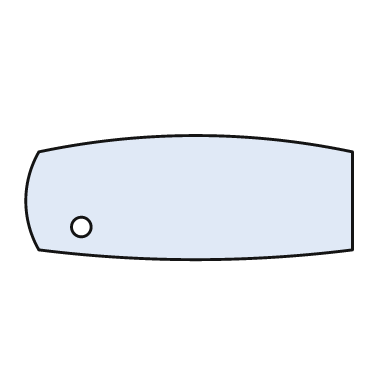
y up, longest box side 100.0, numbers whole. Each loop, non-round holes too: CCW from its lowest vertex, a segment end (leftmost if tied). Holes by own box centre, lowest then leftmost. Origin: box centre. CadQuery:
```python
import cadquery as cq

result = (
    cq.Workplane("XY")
    .moveTo(-46.0, -16.0)
    .threePointArc((2.0, -19.0), (50.0, -16.0))
    .lineTo(50.0, 14.0)
    .threePointArc((2.0, 19.0), (-46.0, 14.0))
    .threePointArc((-50.0, -1.0), (-46.0, -16.0))
    .close()
    .moveTo(-33.0, -9.0)
    .circle(3.0)
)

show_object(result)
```